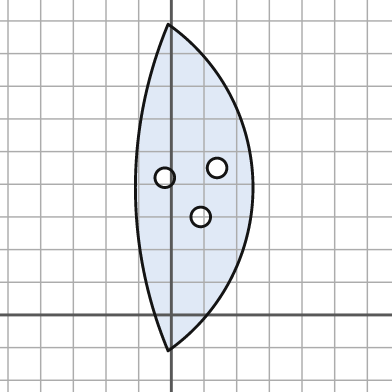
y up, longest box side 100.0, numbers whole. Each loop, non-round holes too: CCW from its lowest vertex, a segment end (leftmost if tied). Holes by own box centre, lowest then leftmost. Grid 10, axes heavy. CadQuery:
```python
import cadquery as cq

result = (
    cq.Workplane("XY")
    .moveTo(-1.0, -11.0)
    .threePointArc((25.0, 39.0), (-1.0, 89.0))
    .threePointArc((-11.0, 39.0), (-1.0, -11.0))
    .close()
    .moveTo(9.0, 30.0)
    .circle(3.0)
    .moveTo(-2.0, 42.0)
    .circle(3.0)
    .moveTo(14.0, 45.0)
    .circle(3.0)
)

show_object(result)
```